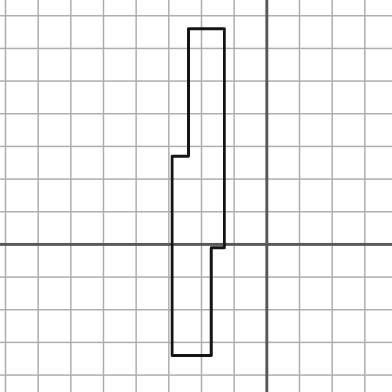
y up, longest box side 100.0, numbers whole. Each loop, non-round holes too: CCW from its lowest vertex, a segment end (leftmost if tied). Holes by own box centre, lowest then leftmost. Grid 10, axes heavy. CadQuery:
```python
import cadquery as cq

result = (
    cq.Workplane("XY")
    .moveTo(-29.0, -34.0)
    .lineTo(-17.0, -34.0)
    .lineTo(-17.0, -1.0)
    .lineTo(-13.0, -1.0)
    .lineTo(-13.0, 66.0)
    .lineTo(-24.0, 66.0)
    .lineTo(-24.0, 27.0)
    .lineTo(-29.0, 27.0)
    .close()
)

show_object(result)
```